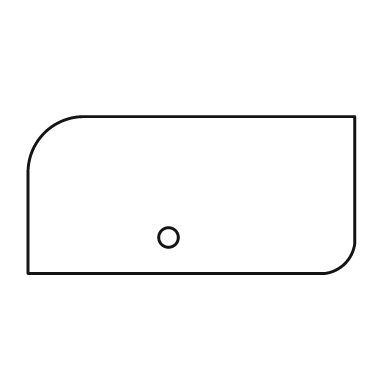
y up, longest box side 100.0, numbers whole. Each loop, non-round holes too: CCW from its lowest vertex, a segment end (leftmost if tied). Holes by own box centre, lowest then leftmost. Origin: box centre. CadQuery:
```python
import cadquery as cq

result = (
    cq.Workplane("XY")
    .moveTo(-50.0, -24.0)
    .lineTo(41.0, -24.0)
    .threePointArc((47.0, -21.0), (50.0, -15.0))
    .lineTo(50.0, 24.0)
    .lineTo(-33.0, 24.0)
    .threePointArc((-45.0, 19.0), (-50.0, 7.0))
    .close()
    .moveTo(-7.0, -13.0)
    .circle(3.0)
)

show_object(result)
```